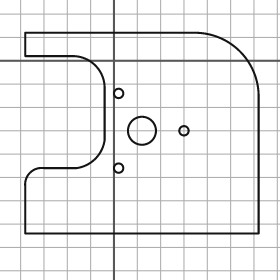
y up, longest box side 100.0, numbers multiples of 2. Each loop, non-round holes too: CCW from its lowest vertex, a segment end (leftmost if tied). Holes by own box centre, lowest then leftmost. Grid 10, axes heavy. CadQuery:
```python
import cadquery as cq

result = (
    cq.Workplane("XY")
    .moveTo(-38.0, -74.0)
    .lineTo(62.0, -74.0)
    .lineTo(62.0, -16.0)
    .threePointArc((54.0, 4.0), (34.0, 12.0))
    .lineTo(-38.0, 12.0)
    .lineTo(-38.0, 2.0)
    .lineTo(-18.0, 2.0)
    .threePointArc((-8.0, -2.0), (-4.0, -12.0))
    .lineTo(-4.0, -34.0)
    .threePointArc((-8.0, -42.0), (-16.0, -46.0))
    .lineTo(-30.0, -46.0)
    .threePointArc((-36.0, -48.0), (-38.0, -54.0))
    .close()
    .moveTo(2.0, -46.0)
    .circle(2.0)
    .moveTo(12.0, -30.0)
    .circle(6.0)
    .moveTo(30.0, -30.0)
    .circle(2.0)
    .moveTo(2.0, -14.0)
    .circle(2.0)
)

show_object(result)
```